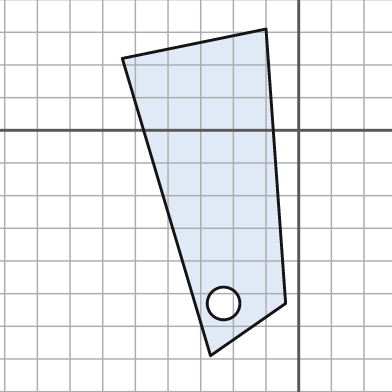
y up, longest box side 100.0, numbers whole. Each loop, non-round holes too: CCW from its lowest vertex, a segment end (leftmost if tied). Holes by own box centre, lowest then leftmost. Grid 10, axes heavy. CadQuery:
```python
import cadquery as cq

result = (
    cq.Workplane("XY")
    .moveTo(-27.0, -69.0)
    .lineTo(-4.0, -53.0)
    .lineTo(-10.0, 31.0)
    .lineTo(-54.0, 22.0)
    .close()
    .moveTo(-23.0, -53.0)
    .circle(5.0)
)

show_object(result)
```